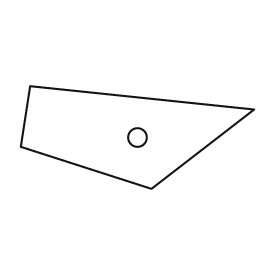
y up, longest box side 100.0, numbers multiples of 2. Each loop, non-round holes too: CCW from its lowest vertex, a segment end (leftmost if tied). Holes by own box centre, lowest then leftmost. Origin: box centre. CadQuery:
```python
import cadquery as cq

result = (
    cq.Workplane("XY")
    .moveTo(6.0, -22.0)
    .lineTo(50.0, 12.0)
    .lineTo(-46.0, 22.0)
    .lineTo(-50.0, -4.0)
    .close()
    .moveTo(0.0, 0.0)
    .circle(4.0)
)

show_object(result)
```